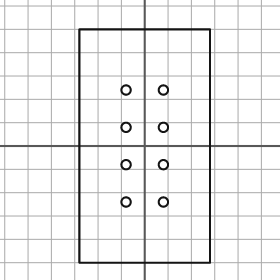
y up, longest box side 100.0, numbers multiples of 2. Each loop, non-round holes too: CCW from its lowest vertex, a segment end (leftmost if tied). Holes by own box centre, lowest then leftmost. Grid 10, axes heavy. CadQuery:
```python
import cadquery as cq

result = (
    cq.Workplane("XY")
    .moveTo(-28.0, -50.0)
    .lineTo(28.0, -50.0)
    .lineTo(28.0, 50.0)
    .lineTo(-28.0, 50.0)
    .close()
    .moveTo(-8.0, -24.0)
    .circle(2.0)
    .moveTo(8.0, -24.0)
    .circle(2.0)
    .moveTo(-8.0, -8.0)
    .circle(2.0)
    .moveTo(8.0, -8.0)
    .circle(2.0)
    .moveTo(-8.0, 8.0)
    .circle(2.0)
    .moveTo(8.0, 8.0)
    .circle(2.0)
    .moveTo(-8.0, 24.0)
    .circle(2.0)
    .moveTo(8.0, 24.0)
    .circle(2.0)
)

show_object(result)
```